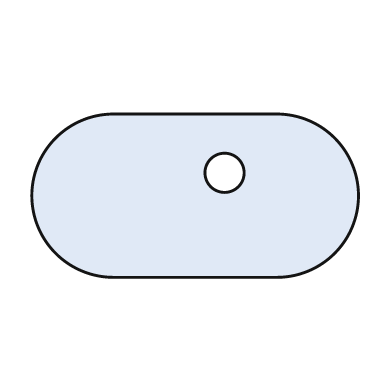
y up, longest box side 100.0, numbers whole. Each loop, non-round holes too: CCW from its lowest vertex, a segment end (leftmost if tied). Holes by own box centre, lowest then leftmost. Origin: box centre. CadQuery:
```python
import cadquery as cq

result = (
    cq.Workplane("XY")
    .moveTo(-25.0, -25.0)
    .lineTo(25.0, -25.0)
    .threePointArc((50.0, 0.0), (25.0, 25.0))
    .lineTo(-25.0, 25.0)
    .threePointArc((-50.0, 0.0), (-25.0, -25.0))
    .close()
    .moveTo(9.0, 7.0)
    .circle(6.0)
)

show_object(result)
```